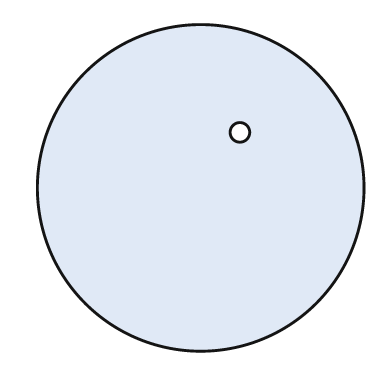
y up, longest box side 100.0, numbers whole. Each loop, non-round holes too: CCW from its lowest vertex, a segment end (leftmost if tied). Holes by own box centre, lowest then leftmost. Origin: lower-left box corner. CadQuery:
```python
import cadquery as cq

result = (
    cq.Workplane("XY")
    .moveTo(50.0, 50.0)
    .circle(50.0)
    .moveTo(62.0, 67.0)
    .circle(3.0)
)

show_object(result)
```